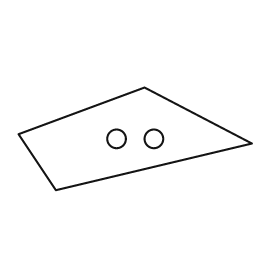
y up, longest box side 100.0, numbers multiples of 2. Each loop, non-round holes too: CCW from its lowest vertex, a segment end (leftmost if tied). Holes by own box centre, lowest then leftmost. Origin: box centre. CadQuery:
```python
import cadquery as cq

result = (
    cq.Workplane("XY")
    .moveTo(-34.0, -22.0)
    .lineTo(50.0, -2.0)
    .lineTo(4.0, 22.0)
    .lineTo(-50.0, 2.0)
    .close()
    .moveTo(-8.0, 0.0)
    .circle(4.0)
    .moveTo(8.0, 0.0)
    .circle(4.0)
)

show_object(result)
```